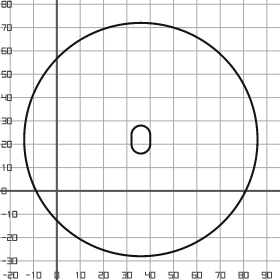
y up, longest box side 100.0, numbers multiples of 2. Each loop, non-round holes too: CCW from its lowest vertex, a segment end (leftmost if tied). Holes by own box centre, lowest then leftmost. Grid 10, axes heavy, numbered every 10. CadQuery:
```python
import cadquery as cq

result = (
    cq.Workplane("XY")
    .moveTo(36.0, 22.0)
    .circle(50.0)
    .moveTo(32.0, 20.0)
    .threePointArc((36.0, 16.0), (40.0, 20.0))
    .lineTo(40.0, 24.0)
    .threePointArc((36.0, 28.0), (32.0, 24.0))
    .close()
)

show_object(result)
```